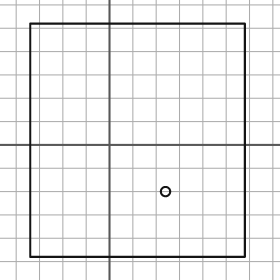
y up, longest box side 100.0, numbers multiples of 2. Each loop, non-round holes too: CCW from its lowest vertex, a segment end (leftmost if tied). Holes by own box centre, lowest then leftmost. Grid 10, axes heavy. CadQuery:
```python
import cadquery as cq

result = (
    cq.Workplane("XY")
    .moveTo(-34.0, -48.0)
    .lineTo(58.0, -48.0)
    .lineTo(58.0, 52.0)
    .lineTo(-34.0, 52.0)
    .close()
    .moveTo(24.0, -20.0)
    .circle(2.0)
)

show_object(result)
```